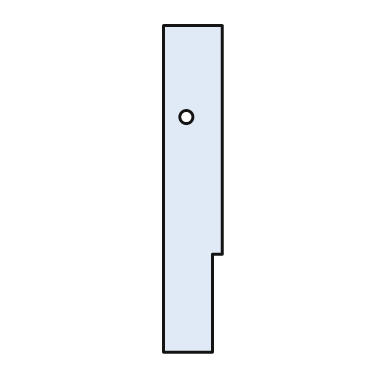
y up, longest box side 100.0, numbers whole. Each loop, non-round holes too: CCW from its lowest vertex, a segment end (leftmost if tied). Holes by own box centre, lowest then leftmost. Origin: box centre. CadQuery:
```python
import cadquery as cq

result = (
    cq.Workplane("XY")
    .moveTo(-9.0, -50.0)
    .lineTo(6.0, -50.0)
    .lineTo(6.0, -20.0)
    .lineTo(9.0, -20.0)
    .lineTo(9.0, 50.0)
    .lineTo(-9.0, 50.0)
    .close()
    .moveTo(-2.0, 22.0)
    .circle(2.0)
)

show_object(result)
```